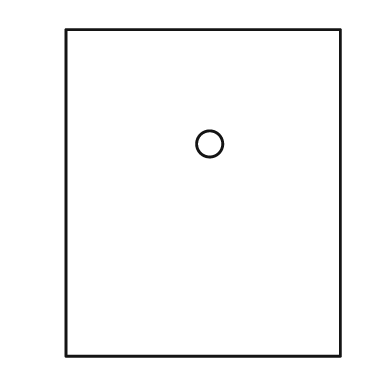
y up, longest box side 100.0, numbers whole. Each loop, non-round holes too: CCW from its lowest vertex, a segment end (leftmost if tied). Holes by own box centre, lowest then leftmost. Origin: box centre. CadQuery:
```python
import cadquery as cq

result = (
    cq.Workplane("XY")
    .moveTo(-42.0, -50.0)
    .lineTo(42.0, -50.0)
    .lineTo(42.0, 50.0)
    .lineTo(-42.0, 50.0)
    .close()
    .moveTo(2.0, 15.0)
    .circle(4.0)
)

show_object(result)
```